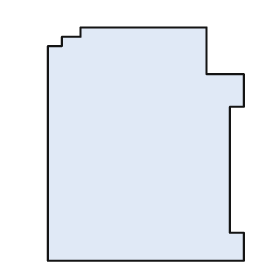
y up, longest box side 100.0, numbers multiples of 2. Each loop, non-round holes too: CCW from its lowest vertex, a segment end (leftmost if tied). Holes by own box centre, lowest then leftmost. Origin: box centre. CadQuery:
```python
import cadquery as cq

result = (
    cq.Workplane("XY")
    .moveTo(-42.0, -50.0)
    .lineTo(42.0, -50.0)
    .lineTo(42.0, -38.0)
    .lineTo(36.0, -38.0)
    .lineTo(36.0, 16.0)
    .lineTo(42.0, 16.0)
    .lineTo(42.0, 30.0)
    .lineTo(26.0, 30.0)
    .lineTo(26.0, 50.0)
    .lineTo(-28.0, 50.0)
    .lineTo(-28.0, 46.0)
    .lineTo(-36.0, 46.0)
    .lineTo(-36.0, 42.0)
    .lineTo(-42.0, 42.0)
    .close()
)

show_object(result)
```